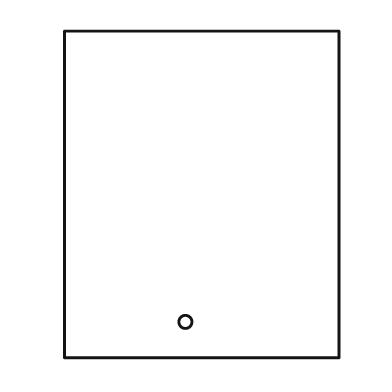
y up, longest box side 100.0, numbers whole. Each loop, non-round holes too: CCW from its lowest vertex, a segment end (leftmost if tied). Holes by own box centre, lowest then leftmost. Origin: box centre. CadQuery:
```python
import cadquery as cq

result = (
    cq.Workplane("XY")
    .moveTo(-42.0, -50.0)
    .lineTo(42.0, -50.0)
    .lineTo(42.0, 50.0)
    .lineTo(-42.0, 50.0)
    .close()
    .moveTo(-5.0, -39.0)
    .circle(2.0)
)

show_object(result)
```